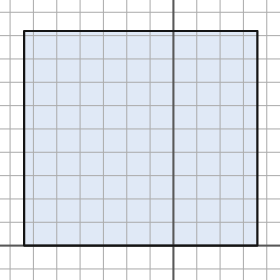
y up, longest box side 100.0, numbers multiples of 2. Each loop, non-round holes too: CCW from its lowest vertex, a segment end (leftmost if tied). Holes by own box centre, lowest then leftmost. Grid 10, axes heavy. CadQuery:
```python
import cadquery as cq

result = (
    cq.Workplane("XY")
    .moveTo(-64.0, 0.0)
    .lineTo(36.0, 0.0)
    .lineTo(36.0, 92.0)
    .lineTo(-64.0, 92.0)
    .close()
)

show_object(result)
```